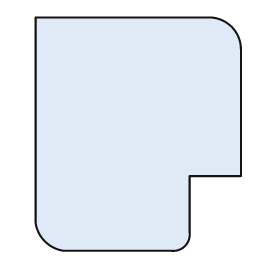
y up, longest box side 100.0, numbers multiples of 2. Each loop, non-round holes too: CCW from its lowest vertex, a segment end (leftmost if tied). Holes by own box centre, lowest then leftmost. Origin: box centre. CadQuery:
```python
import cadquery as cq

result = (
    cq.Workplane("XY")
    .moveTo(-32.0, -50.0)
    .lineTo(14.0, -50.0)
    .threePointArc((20.0, -48.0), (22.0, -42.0))
    .lineTo(22.0, -18.0)
    .lineTo(44.0, -18.0)
    .lineTo(44.0, 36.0)
    .threePointArc((40.0, 46.0), (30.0, 50.0))
    .lineTo(-44.0, 50.0)
    .lineTo(-44.0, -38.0)
    .threePointArc((-40.0, -46.0), (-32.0, -50.0))
    .close()
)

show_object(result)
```